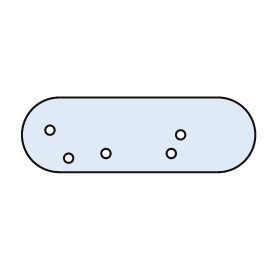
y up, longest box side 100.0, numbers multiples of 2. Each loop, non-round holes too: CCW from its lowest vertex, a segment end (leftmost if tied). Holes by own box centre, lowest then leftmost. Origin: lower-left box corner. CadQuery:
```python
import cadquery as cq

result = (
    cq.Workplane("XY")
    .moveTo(16.0, 0.0)
    .lineTo(84.0, 0.0)
    .threePointArc((100.0, 16.0), (84.0, 32.0))
    .lineTo(16.0, 32.0)
    .threePointArc((0.0, 16.0), (16.0, 0.0))
    .close()
    .moveTo(20.0, 6.0)
    .circle(2.0)
    .moveTo(36.0, 8.0)
    .circle(2.0)
    .moveTo(64.0, 8.0)
    .circle(2.0)
    .moveTo(68.0, 16.0)
    .circle(2.0)
    .moveTo(12.0, 18.0)
    .circle(2.0)
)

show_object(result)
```